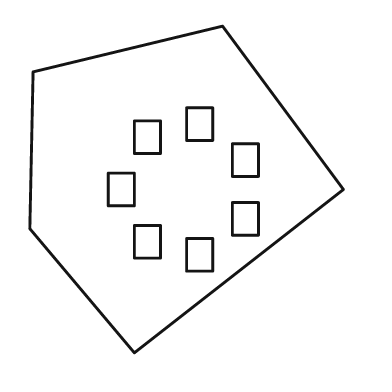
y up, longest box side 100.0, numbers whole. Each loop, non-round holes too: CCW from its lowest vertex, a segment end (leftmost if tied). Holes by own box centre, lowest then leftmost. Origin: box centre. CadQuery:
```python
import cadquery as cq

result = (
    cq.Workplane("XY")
    .moveTo(-16.0, -50.0)
    .lineTo(48.0, 0.0)
    .lineTo(11.0, 50.0)
    .lineTo(-47.0, 36.0)
    .lineTo(-48.0, -12.0)
    .close()
    .moveTo(0.0, -25.0)
    .lineTo(8.0, -25.0)
    .lineTo(8.0, -15.0)
    .lineTo(0.0, -15.0)
    .close()
    .moveTo(-16.0, -21.0)
    .lineTo(-8.0, -21.0)
    .lineTo(-8.0, -11.0)
    .lineTo(-16.0, -11.0)
    .close()
    .moveTo(14.0, -14.0)
    .lineTo(22.0, -14.0)
    .lineTo(22.0, -4.0)
    .lineTo(14.0, -4.0)
    .close()
    .moveTo(-24.0, -5.0)
    .lineTo(-16.0, -5.0)
    .lineTo(-16.0, 5.0)
    .lineTo(-24.0, 5.0)
    .close()
    .moveTo(14.0, 4.0)
    .lineTo(22.0, 4.0)
    .lineTo(22.0, 14.0)
    .lineTo(14.0, 14.0)
    .close()
    .moveTo(-16.0, 11.0)
    .lineTo(-8.0, 11.0)
    .lineTo(-8.0, 21.0)
    .lineTo(-16.0, 21.0)
    .close()
    .moveTo(0.0, 15.0)
    .lineTo(8.0, 15.0)
    .lineTo(8.0, 25.0)
    .lineTo(0.0, 25.0)
    .close()
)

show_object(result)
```